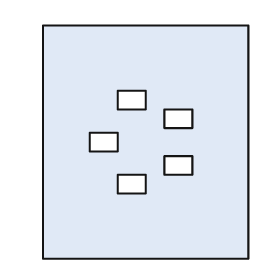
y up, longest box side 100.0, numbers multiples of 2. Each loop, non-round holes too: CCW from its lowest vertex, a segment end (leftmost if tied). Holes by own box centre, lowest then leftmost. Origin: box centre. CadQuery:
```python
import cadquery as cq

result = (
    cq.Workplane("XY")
    .moveTo(-44.0, -50.0)
    .lineTo(44.0, -50.0)
    .lineTo(44.0, 50.0)
    .lineTo(-44.0, 50.0)
    .close()
    .moveTo(-12.0, -22.0)
    .lineTo(0.0, -22.0)
    .lineTo(0.0, -14.0)
    .lineTo(-12.0, -14.0)
    .close()
    .moveTo(8.0, -14.0)
    .lineTo(20.0, -14.0)
    .lineTo(20.0, -6.0)
    .lineTo(8.0, -6.0)
    .close()
    .moveTo(-24.0, -4.0)
    .lineTo(-12.0, -4.0)
    .lineTo(-12.0, 4.0)
    .lineTo(-24.0, 4.0)
    .close()
    .moveTo(8.0, 6.0)
    .lineTo(20.0, 6.0)
    .lineTo(20.0, 14.0)
    .lineTo(8.0, 14.0)
    .close()
    .moveTo(-12.0, 14.0)
    .lineTo(0.0, 14.0)
    .lineTo(0.0, 22.0)
    .lineTo(-12.0, 22.0)
    .close()
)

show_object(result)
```